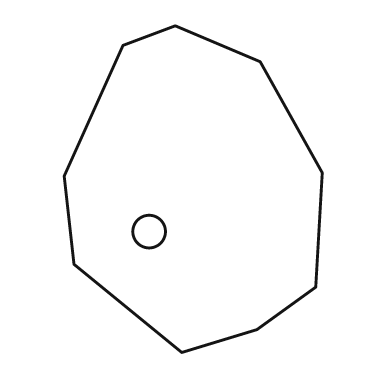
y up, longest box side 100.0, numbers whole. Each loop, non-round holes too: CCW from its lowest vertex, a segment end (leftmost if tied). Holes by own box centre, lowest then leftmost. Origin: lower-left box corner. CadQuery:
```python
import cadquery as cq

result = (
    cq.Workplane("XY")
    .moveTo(36.0, 0.0)
    .lineTo(59.0, 7.0)
    .lineTo(77.0, 20.0)
    .lineTo(79.0, 55.0)
    .lineTo(60.0, 89.0)
    .lineTo(34.0, 100.0)
    .lineTo(18.0, 94.0)
    .lineTo(0.0, 54.0)
    .lineTo(3.0, 27.0)
    .close()
    .moveTo(26.0, 37.0)
    .circle(5.0)
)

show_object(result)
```